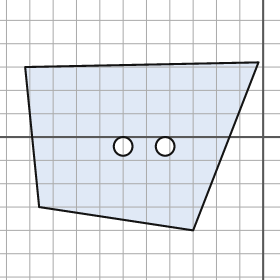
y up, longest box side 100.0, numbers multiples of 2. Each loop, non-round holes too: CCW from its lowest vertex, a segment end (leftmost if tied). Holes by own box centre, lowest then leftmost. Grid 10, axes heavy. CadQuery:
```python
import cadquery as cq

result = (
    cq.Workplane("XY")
    .moveTo(-30.0, -40.0)
    .lineTo(-2.0, 32.0)
    .lineTo(-102.0, 30.0)
    .lineTo(-96.0, -30.0)
    .close()
    .moveTo(-60.0, -4.0)
    .circle(4.0)
    .moveTo(-42.0, -4.0)
    .circle(4.0)
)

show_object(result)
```